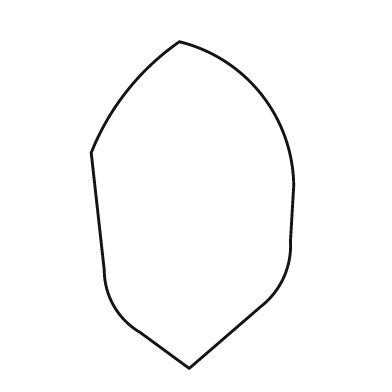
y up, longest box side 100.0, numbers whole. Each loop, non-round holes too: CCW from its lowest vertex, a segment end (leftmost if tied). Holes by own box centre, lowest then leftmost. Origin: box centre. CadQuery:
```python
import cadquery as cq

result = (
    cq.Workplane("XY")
    .moveTo(-1.0, -50.0)
    .lineTo(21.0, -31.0)
    .threePointArc((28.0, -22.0), (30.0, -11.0))
    .lineTo(31.0, 6.0)
    .threePointArc((21.0, 34.0), (-4.0, 50.0))
    .threePointArc((-20.0, 35.0), (-31.0, 16.0))
    .lineTo(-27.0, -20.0)
    .threePointArc((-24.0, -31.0), (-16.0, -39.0))
    .close()
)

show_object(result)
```